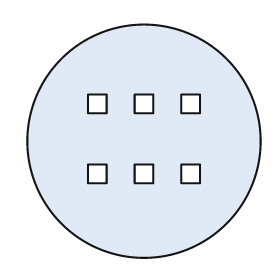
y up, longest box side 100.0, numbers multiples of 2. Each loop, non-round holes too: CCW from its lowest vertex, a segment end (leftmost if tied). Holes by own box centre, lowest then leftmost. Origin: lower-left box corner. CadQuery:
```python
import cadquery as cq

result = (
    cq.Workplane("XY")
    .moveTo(50.0, 50.0)
    .circle(50.0)
    .moveTo(26.0, 32.0)
    .lineTo(34.0, 32.0)
    .lineTo(34.0, 40.0)
    .lineTo(26.0, 40.0)
    .close()
    .moveTo(46.0, 32.0)
    .lineTo(54.0, 32.0)
    .lineTo(54.0, 40.0)
    .lineTo(46.0, 40.0)
    .close()
    .moveTo(66.0, 32.0)
    .lineTo(74.0, 32.0)
    .lineTo(74.0, 40.0)
    .lineTo(66.0, 40.0)
    .close()
    .moveTo(26.0, 62.0)
    .lineTo(34.0, 62.0)
    .lineTo(34.0, 70.0)
    .lineTo(26.0, 70.0)
    .close()
    .moveTo(46.0, 62.0)
    .lineTo(54.0, 62.0)
    .lineTo(54.0, 70.0)
    .lineTo(46.0, 70.0)
    .close()
    .moveTo(66.0, 62.0)
    .lineTo(74.0, 62.0)
    .lineTo(74.0, 70.0)
    .lineTo(66.0, 70.0)
    .close()
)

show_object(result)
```